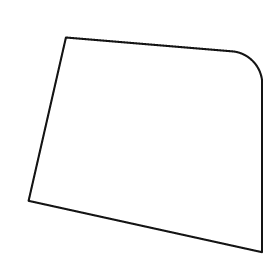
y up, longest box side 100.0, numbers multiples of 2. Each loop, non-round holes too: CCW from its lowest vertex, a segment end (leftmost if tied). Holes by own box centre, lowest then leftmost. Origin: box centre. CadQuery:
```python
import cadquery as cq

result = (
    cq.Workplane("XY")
    .moveTo(50.0, -46.0)
    .lineTo(50.0, 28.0)
    .threePointArc((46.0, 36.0), (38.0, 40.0))
    .lineTo(-34.0, 46.0)
    .lineTo(-50.0, -24.0)
    .close()
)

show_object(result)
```